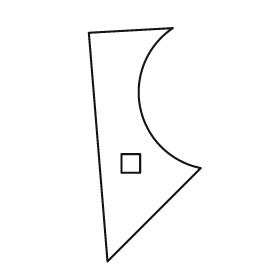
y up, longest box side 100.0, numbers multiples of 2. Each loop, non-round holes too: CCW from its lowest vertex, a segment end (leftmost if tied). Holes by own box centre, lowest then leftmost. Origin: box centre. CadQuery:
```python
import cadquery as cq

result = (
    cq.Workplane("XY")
    .moveTo(-16.0, -50.0)
    .lineTo(24.0, -10.0)
    .threePointArc((-2.0, 16.0), (12.0, 50.0))
    .lineTo(-24.0, 48.0)
    .close()
    .moveTo(-10.0, -12.0)
    .lineTo(-2.0, -12.0)
    .lineTo(-2.0, -4.0)
    .lineTo(-10.0, -4.0)
    .close()
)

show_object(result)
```